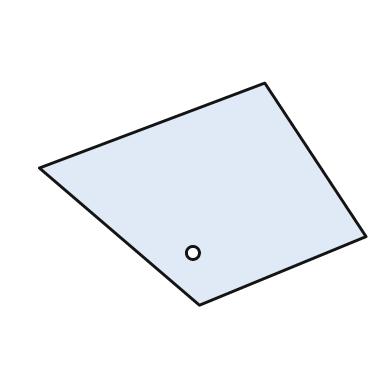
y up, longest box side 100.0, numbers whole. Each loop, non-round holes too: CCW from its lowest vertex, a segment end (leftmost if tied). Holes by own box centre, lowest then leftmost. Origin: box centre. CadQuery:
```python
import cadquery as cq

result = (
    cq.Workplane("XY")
    .moveTo(-1.0, -34.0)
    .lineTo(50.0, -13.0)
    .lineTo(19.0, 34.0)
    .lineTo(-50.0, 8.0)
    .close()
    .moveTo(-3.0, -18.0)
    .circle(2.0)
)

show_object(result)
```